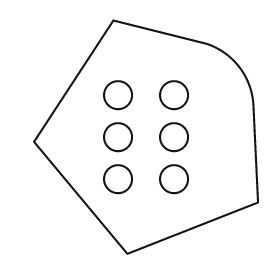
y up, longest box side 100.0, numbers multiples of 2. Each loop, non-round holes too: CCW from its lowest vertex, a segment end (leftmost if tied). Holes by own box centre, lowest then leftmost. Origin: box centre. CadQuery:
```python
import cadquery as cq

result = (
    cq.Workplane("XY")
    .moveTo(-8.0, -50.0)
    .lineTo(48.0, -28.0)
    .lineTo(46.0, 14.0)
    .threePointArc((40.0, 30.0), (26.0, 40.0))
    .lineTo(-14.0, 50.0)
    .lineTo(-48.0, -2.0)
    .close()
    .moveTo(-12.0, -18.0)
    .circle(6.0)
    .moveTo(12.0, -18.0)
    .circle(6.0)
    .moveTo(-12.0, 0.0)
    .circle(6.0)
    .moveTo(12.0, 0.0)
    .circle(6.0)
    .moveTo(-12.0, 18.0)
    .circle(6.0)
    .moveTo(12.0, 18.0)
    .circle(6.0)
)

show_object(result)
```